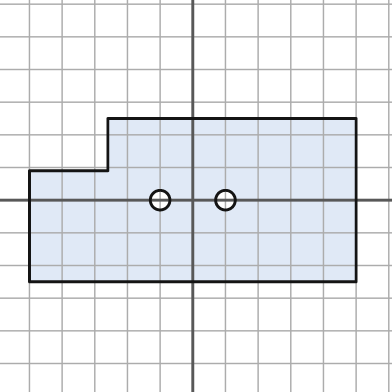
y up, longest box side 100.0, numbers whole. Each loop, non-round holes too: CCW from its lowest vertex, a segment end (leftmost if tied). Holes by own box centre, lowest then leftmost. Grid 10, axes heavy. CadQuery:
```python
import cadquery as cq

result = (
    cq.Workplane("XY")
    .moveTo(-50.0, -25.0)
    .lineTo(50.0, -25.0)
    .lineTo(50.0, 25.0)
    .lineTo(-26.0, 25.0)
    .lineTo(-26.0, 9.0)
    .lineTo(-50.0, 9.0)
    .close()
    .moveTo(-10.0, 0.0)
    .circle(3.0)
    .moveTo(10.0, 0.0)
    .circle(3.0)
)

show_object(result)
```